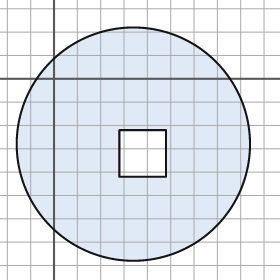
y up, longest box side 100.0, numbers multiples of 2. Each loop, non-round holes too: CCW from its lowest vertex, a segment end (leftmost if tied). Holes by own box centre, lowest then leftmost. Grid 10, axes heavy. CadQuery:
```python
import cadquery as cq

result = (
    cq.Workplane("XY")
    .moveTo(34.0, -28.0)
    .circle(50.0)
    .moveTo(28.0, -42.0)
    .lineTo(48.0, -42.0)
    .lineTo(48.0, -22.0)
    .lineTo(28.0, -22.0)
    .close()
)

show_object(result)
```